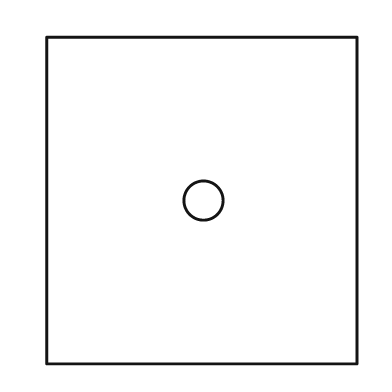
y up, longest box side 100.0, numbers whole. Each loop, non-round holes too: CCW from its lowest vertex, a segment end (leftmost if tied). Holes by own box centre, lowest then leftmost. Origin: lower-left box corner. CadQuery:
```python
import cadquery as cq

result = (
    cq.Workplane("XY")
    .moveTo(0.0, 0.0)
    .lineTo(95.0, 0.0)
    .lineTo(95.0, 100.0)
    .lineTo(0.0, 100.0)
    .close()
    .moveTo(48.0, 50.0)
    .circle(6.0)
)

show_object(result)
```